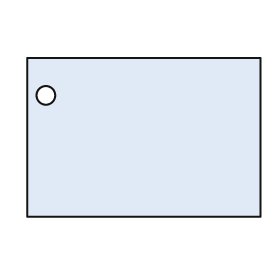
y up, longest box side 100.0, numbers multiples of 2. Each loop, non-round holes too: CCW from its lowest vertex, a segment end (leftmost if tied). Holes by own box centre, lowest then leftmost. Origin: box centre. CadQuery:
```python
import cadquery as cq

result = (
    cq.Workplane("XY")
    .moveTo(-50.0, -34.0)
    .lineTo(50.0, -34.0)
    .lineTo(50.0, 34.0)
    .lineTo(-50.0, 34.0)
    .close()
    .moveTo(-42.0, 18.0)
    .circle(4.0)
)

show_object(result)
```